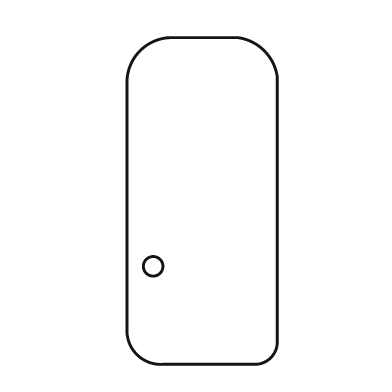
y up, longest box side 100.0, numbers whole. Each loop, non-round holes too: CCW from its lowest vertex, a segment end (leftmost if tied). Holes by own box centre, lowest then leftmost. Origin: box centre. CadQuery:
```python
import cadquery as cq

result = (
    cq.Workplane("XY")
    .moveTo(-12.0, -50.0)
    .lineTo(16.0, -50.0)
    .threePointArc((21.0, -48.0), (23.0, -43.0))
    .lineTo(23.0, 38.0)
    .threePointArc((19.0, 46.0), (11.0, 50.0))
    .lineTo(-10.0, 50.0)
    .threePointArc((-19.0, 46.0), (-23.0, 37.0))
    .lineTo(-23.0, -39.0)
    .threePointArc((-20.0, -47.0), (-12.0, -50.0))
    .close()
    .moveTo(-15.0, -20.0)
    .circle(3.0)
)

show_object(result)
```